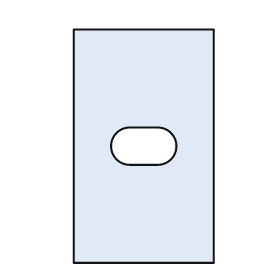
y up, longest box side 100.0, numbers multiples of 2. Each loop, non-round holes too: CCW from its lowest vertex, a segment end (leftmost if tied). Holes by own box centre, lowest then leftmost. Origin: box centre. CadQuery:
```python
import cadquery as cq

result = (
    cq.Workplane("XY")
    .moveTo(-30.0, -50.0)
    .lineTo(30.0, -50.0)
    .lineTo(30.0, 50.0)
    .lineTo(-30.0, 50.0)
    .close()
    .moveTo(-6.0, -8.0)
    .lineTo(6.0, -8.0)
    .threePointArc((14.0, 0.0), (6.0, 8.0))
    .lineTo(-6.0, 8.0)
    .threePointArc((-14.0, 0.0), (-6.0, -8.0))
    .close()
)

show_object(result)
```